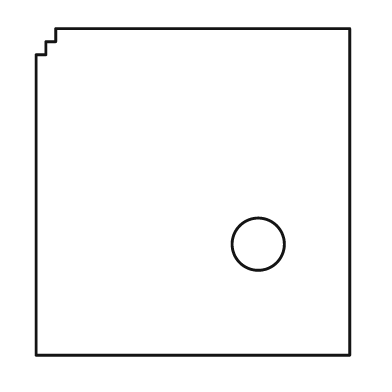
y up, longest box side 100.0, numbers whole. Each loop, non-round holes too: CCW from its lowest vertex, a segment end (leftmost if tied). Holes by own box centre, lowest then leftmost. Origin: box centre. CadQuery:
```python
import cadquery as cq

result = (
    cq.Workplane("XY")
    .moveTo(-48.0, -50.0)
    .lineTo(48.0, -50.0)
    .lineTo(48.0, 50.0)
    .lineTo(-42.0, 50.0)
    .lineTo(-42.0, 46.0)
    .lineTo(-45.0, 46.0)
    .lineTo(-45.0, 42.0)
    .lineTo(-48.0, 42.0)
    .close()
    .moveTo(20.0, -16.0)
    .circle(8.0)
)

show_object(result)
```